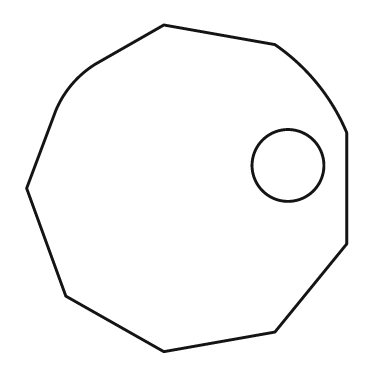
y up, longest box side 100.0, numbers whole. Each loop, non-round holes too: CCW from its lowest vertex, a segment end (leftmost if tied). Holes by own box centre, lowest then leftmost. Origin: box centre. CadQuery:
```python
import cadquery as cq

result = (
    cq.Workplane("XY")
    .moveTo(-7.0, -50.0)
    .lineTo(27.0, -44.0)
    .lineTo(49.0, -17.0)
    .lineTo(49.0, 17.0)
    .threePointArc((40.0, 32.0), (27.0, 44.0))
    .lineTo(-7.0, 50.0)
    .lineTo(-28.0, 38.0)
    .threePointArc((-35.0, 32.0), (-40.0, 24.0))
    .lineTo(-49.0, 0.0)
    .lineTo(-37.0, -33.0)
    .close()
    .moveTo(31.0, 7.0)
    .circle(11.0)
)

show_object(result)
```